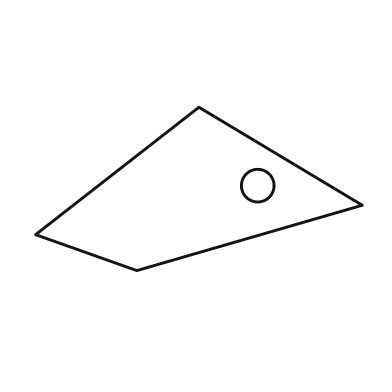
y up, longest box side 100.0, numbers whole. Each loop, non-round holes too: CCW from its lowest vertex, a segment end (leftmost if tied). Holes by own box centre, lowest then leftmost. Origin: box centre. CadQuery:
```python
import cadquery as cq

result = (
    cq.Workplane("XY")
    .moveTo(-19.0, -25.0)
    .lineTo(50.0, -5.0)
    .lineTo(0.0, 25.0)
    .lineTo(-50.0, -14.0)
    .close()
    .moveTo(18.0, 1.0)
    .circle(5.0)
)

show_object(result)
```